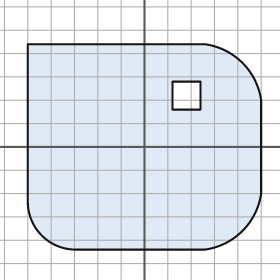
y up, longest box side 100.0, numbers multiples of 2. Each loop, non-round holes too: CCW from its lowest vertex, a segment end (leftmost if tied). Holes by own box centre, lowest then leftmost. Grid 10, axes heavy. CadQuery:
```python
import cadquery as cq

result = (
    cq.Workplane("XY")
    .moveTo(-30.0, -44.0)
    .lineTo(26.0, -44.0)
    .threePointArc((42.0, -36.0), (50.0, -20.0))
    .lineTo(50.0, 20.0)
    .threePointArc((42.0, 36.0), (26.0, 44.0))
    .lineTo(-50.0, 44.0)
    .lineTo(-50.0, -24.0)
    .threePointArc((-44.0, -38.0), (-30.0, -44.0))
    .close()
    .moveTo(12.0, 16.0)
    .lineTo(24.0, 16.0)
    .lineTo(24.0, 28.0)
    .lineTo(12.0, 28.0)
    .close()
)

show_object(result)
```